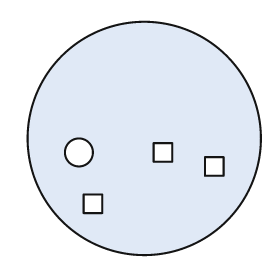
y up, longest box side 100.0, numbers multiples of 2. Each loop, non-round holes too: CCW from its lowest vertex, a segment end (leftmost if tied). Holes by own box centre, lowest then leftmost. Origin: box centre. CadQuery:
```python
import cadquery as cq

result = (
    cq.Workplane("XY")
    .moveTo(0.0, 0.0)
    .circle(50.0)
    .moveTo(-26.0, -32.0)
    .lineTo(-18.0, -32.0)
    .lineTo(-18.0, -24.0)
    .lineTo(-26.0, -24.0)
    .close()
    .moveTo(26.0, -16.0)
    .lineTo(34.0, -16.0)
    .lineTo(34.0, -8.0)
    .lineTo(26.0, -8.0)
    .close()
    .moveTo(-28.0, -6.0)
    .circle(6.0)
    .moveTo(4.0, -10.0)
    .lineTo(12.0, -10.0)
    .lineTo(12.0, -2.0)
    .lineTo(4.0, -2.0)
    .close()
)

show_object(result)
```